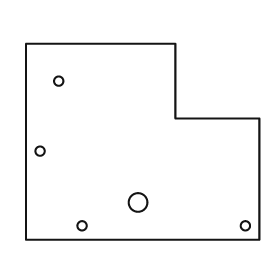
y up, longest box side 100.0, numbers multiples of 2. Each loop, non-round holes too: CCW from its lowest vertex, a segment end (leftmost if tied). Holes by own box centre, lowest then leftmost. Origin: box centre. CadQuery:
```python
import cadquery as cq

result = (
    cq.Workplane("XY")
    .moveTo(-50.0, -42.0)
    .lineTo(50.0, -42.0)
    .lineTo(50.0, 10.0)
    .lineTo(14.0, 10.0)
    .lineTo(14.0, 42.0)
    .lineTo(-50.0, 42.0)
    .close()
    .moveTo(-26.0, -36.0)
    .circle(2.0)
    .moveTo(44.0, -36.0)
    .circle(2.0)
    .moveTo(-2.0, -26.0)
    .circle(4.0)
    .moveTo(-44.0, -4.0)
    .circle(2.0)
    .moveTo(-36.0, 26.0)
    .circle(2.0)
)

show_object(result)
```